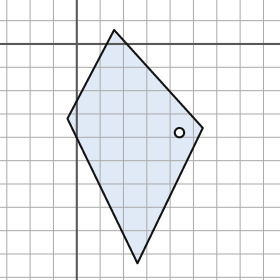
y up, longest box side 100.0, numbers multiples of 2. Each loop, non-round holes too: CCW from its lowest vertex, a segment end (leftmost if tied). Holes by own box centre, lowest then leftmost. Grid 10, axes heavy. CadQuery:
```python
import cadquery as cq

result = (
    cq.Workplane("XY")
    .moveTo(26.0, -94.0)
    .lineTo(54.0, -36.0)
    .lineTo(16.0, 6.0)
    .lineTo(-4.0, -32.0)
    .close()
    .moveTo(44.0, -38.0)
    .circle(2.0)
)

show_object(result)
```